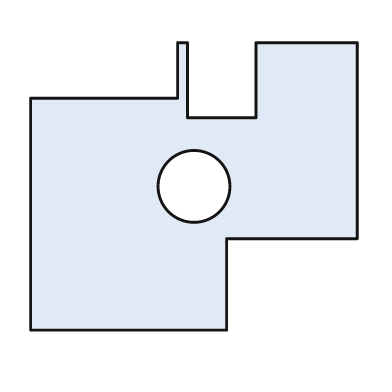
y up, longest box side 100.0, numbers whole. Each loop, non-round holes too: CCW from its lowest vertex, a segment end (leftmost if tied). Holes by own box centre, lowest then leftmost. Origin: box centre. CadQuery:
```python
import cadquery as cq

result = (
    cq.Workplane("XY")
    .moveTo(-50.0, -44.0)
    .lineTo(10.0, -44.0)
    .lineTo(10.0, -16.0)
    .lineTo(50.0, -16.0)
    .lineTo(50.0, 44.0)
    .lineTo(19.0, 44.0)
    .lineTo(19.0, 21.0)
    .lineTo(-2.0, 21.0)
    .lineTo(-2.0, 44.0)
    .lineTo(-5.0, 44.0)
    .lineTo(-5.0, 27.0)
    .lineTo(-50.0, 27.0)
    .close()
    .moveTo(0.0, 0.0)
    .circle(11.0)
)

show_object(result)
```